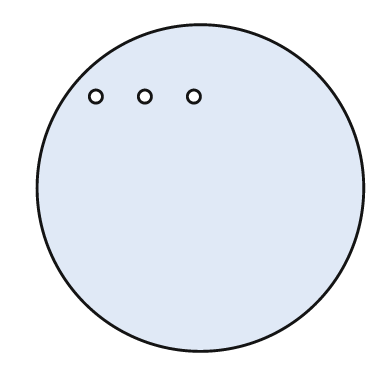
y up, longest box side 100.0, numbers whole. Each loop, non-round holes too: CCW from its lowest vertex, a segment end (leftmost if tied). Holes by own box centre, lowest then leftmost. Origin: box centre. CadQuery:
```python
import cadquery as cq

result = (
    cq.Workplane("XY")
    .moveTo(0.0, 0.0)
    .circle(50.0)
    .moveTo(-32.0, 28.0)
    .circle(2.0)
    .moveTo(-17.0, 28.0)
    .circle(2.0)
    .moveTo(-2.0, 28.0)
    .circle(2.0)
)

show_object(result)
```